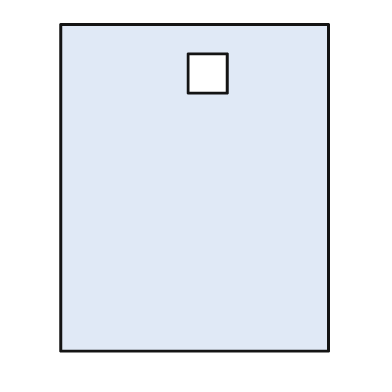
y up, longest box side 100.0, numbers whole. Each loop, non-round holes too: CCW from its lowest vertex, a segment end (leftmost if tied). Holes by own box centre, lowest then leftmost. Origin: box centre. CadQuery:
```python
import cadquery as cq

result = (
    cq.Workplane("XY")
    .moveTo(-41.0, -50.0)
    .lineTo(41.0, -50.0)
    .lineTo(41.0, 50.0)
    .lineTo(-41.0, 50.0)
    .close()
    .moveTo(-2.0, 29.0)
    .lineTo(10.0, 29.0)
    .lineTo(10.0, 41.0)
    .lineTo(-2.0, 41.0)
    .close()
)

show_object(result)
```